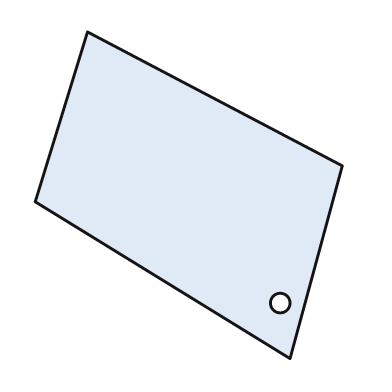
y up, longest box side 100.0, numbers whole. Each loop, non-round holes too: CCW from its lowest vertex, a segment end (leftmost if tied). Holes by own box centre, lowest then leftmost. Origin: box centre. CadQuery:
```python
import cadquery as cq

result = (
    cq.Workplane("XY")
    .moveTo(31.0, -50.0)
    .lineTo(47.0, 9.0)
    .lineTo(-31.0, 50.0)
    .lineTo(-47.0, -2.0)
    .close()
    .moveTo(28.0, -33.0)
    .circle(3.0)
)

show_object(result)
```